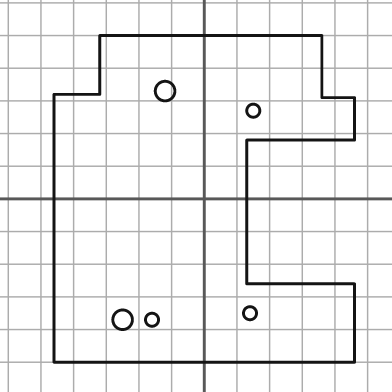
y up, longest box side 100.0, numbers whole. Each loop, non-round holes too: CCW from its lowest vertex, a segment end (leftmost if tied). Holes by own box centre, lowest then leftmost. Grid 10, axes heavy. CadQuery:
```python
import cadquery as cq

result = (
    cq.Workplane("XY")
    .moveTo(-46.0, -50.0)
    .lineTo(46.0, -50.0)
    .lineTo(46.0, -26.0)
    .lineTo(13.0, -26.0)
    .lineTo(13.0, 18.0)
    .lineTo(46.0, 18.0)
    .lineTo(46.0, 31.0)
    .lineTo(36.0, 31.0)
    .lineTo(36.0, 50.0)
    .lineTo(-32.0, 50.0)
    .lineTo(-32.0, 32.0)
    .lineTo(-46.0, 32.0)
    .close()
    .moveTo(-25.0, -37.0)
    .circle(3.0)
    .moveTo(-16.0, -37.0)
    .circle(2.0)
    .moveTo(14.0, -35.0)
    .circle(2.0)
    .moveTo(15.0, 27.0)
    .circle(2.0)
    .moveTo(-12.0, 33.0)
    .circle(3.0)
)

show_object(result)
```